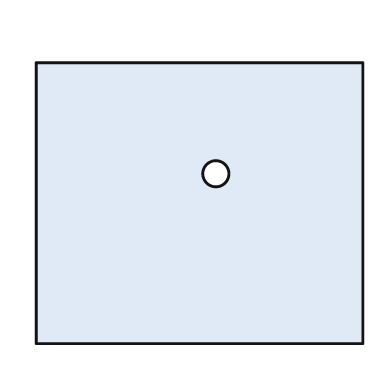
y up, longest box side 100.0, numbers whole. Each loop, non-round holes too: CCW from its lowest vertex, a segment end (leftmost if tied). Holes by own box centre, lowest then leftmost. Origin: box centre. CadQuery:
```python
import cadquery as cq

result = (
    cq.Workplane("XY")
    .moveTo(-50.0, -43.0)
    .lineTo(50.0, -43.0)
    .lineTo(50.0, 43.0)
    .lineTo(-50.0, 43.0)
    .close()
    .moveTo(5.0, 9.0)
    .circle(4.0)
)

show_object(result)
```